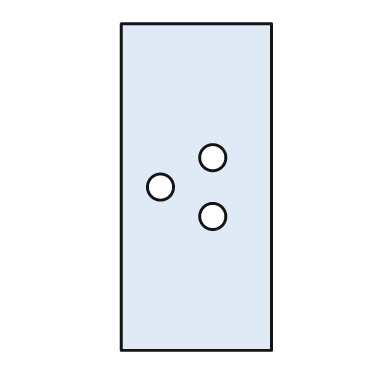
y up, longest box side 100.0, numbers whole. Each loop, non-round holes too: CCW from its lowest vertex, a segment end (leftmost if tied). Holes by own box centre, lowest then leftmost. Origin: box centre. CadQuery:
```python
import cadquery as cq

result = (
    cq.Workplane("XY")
    .moveTo(-23.0, -50.0)
    .lineTo(23.0, -50.0)
    .lineTo(23.0, 50.0)
    .lineTo(-23.0, 50.0)
    .close()
    .moveTo(5.0, -9.0)
    .circle(4.0)
    .moveTo(-11.0, 0.0)
    .circle(4.0)
    .moveTo(5.0, 9.0)
    .circle(4.0)
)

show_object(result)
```